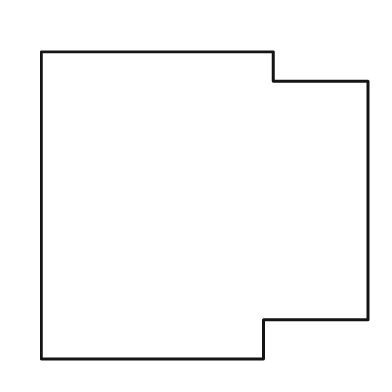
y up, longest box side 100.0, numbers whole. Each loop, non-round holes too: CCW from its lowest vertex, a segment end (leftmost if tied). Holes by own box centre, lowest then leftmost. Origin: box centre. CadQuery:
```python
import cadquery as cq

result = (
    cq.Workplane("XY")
    .moveTo(-50.0, -47.0)
    .lineTo(18.0, -47.0)
    .lineTo(18.0, -35.0)
    .lineTo(50.0, -35.0)
    .lineTo(50.0, 38.0)
    .lineTo(21.0, 38.0)
    .lineTo(21.0, 47.0)
    .lineTo(-50.0, 47.0)
    .close()
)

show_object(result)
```